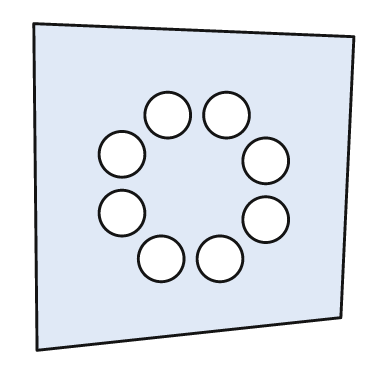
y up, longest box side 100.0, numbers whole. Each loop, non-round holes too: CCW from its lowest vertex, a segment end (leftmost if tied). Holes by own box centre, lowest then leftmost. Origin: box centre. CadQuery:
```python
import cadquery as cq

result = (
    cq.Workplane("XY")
    .moveTo(-48.0, -50.0)
    .lineTo(45.0, -40.0)
    .lineTo(49.0, 46.0)
    .lineTo(-49.0, 50.0)
    .close()
    .moveTo(-10.0, -22.0)
    .circle(7.0)
    .moveTo(8.0, -22.0)
    .circle(7.0)
    .moveTo(22.0, -10.0)
    .circle(7.0)
    .moveTo(-22.0, -8.0)
    .circle(7.0)
    .moveTo(22.0, 8.0)
    .circle(7.0)
    .moveTo(-22.0, 10.0)
    .circle(7.0)
    .moveTo(-8.0, 22.0)
    .circle(7.0)
    .moveTo(10.0, 22.0)
    .circle(7.0)
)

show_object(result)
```